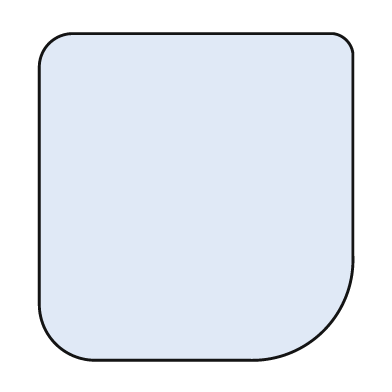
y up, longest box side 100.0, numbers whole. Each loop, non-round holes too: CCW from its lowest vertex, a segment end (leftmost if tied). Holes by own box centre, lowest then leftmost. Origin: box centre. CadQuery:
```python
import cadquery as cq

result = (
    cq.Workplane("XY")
    .moveTo(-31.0, -50.0)
    .lineTo(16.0, -50.0)
    .threePointArc((39.0, -41.0), (48.0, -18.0))
    .lineTo(48.0, 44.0)
    .threePointArc((46.0, 48.0), (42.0, 50.0))
    .lineTo(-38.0, 50.0)
    .threePointArc((-45.0, 47.0), (-48.0, 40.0))
    .lineTo(-48.0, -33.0)
    .threePointArc((-43.0, -45.0), (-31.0, -50.0))
    .close()
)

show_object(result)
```